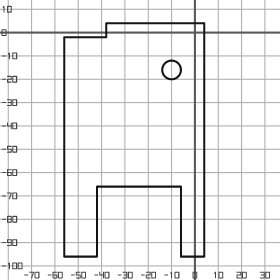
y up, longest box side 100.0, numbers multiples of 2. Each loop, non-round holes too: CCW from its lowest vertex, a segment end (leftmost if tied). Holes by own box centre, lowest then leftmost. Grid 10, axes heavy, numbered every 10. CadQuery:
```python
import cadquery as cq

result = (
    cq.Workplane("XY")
    .moveTo(-56.0, -96.0)
    .lineTo(-42.0, -96.0)
    .lineTo(-42.0, -66.0)
    .lineTo(-6.0, -66.0)
    .lineTo(-6.0, -96.0)
    .lineTo(4.0, -96.0)
    .lineTo(4.0, 4.0)
    .lineTo(-38.0, 4.0)
    .lineTo(-38.0, -2.0)
    .lineTo(-56.0, -2.0)
    .close()
    .moveTo(-10.0, -16.0)
    .circle(4.0)
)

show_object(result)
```